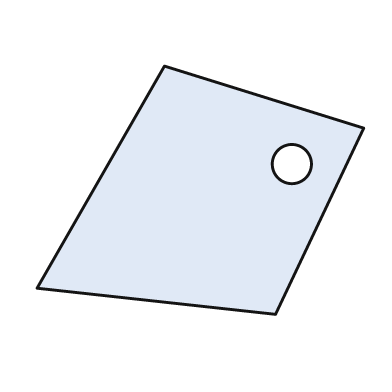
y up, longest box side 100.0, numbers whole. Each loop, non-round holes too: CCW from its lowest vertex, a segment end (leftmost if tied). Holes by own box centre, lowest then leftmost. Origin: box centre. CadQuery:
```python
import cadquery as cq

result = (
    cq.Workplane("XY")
    .moveTo(23.0, -38.0)
    .lineTo(50.0, 19.0)
    .lineTo(-11.0, 38.0)
    .lineTo(-50.0, -30.0)
    .close()
    .moveTo(28.0, 8.0)
    .circle(6.0)
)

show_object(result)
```